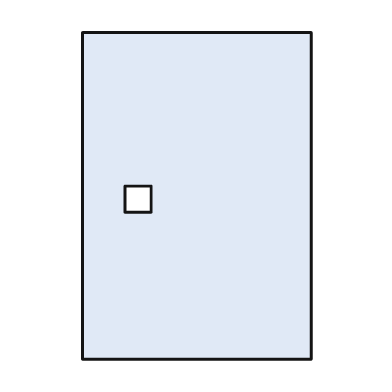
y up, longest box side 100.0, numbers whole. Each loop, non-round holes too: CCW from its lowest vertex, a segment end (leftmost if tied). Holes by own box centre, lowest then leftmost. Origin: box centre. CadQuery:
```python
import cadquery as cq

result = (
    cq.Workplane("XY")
    .moveTo(-35.0, -50.0)
    .lineTo(35.0, -50.0)
    .lineTo(35.0, 50.0)
    .lineTo(-35.0, 50.0)
    .close()
    .moveTo(-22.0, -5.0)
    .lineTo(-14.0, -5.0)
    .lineTo(-14.0, 3.0)
    .lineTo(-22.0, 3.0)
    .close()
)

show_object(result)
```